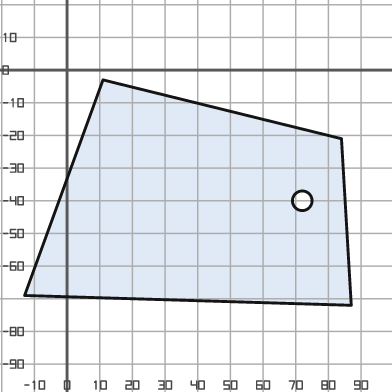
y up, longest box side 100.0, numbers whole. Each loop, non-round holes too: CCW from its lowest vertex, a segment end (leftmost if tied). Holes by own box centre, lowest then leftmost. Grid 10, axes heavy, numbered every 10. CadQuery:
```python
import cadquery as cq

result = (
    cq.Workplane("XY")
    .moveTo(87.0, -72.0)
    .lineTo(84.0, -21.0)
    .lineTo(11.0, -3.0)
    .lineTo(-13.0, -69.0)
    .close()
    .moveTo(72.0, -40.0)
    .circle(3.0)
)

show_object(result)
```